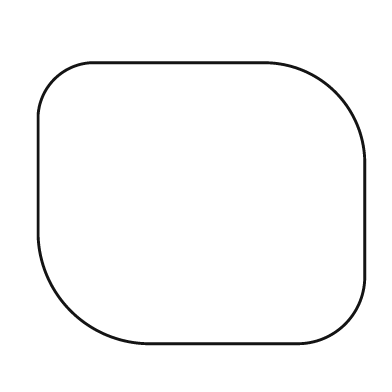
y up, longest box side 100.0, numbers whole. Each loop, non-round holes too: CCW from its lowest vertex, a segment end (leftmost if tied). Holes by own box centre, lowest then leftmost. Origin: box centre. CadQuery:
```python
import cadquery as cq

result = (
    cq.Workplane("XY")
    .moveTo(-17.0, -43.0)
    .lineTo(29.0, -43.0)
    .threePointArc((44.0, -37.0), (50.0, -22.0))
    .lineTo(50.0, 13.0)
    .threePointArc((41.0, 34.0), (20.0, 43.0))
    .lineTo(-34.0, 43.0)
    .threePointArc((-45.0, 38.0), (-50.0, 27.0))
    .lineTo(-50.0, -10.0)
    .threePointArc((-40.0, -33.0), (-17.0, -43.0))
    .close()
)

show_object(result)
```